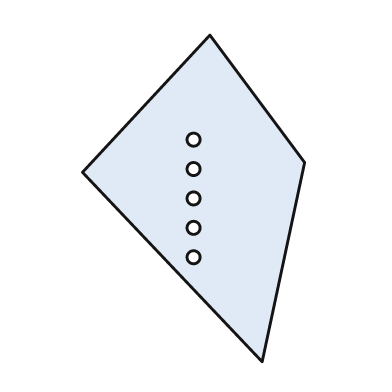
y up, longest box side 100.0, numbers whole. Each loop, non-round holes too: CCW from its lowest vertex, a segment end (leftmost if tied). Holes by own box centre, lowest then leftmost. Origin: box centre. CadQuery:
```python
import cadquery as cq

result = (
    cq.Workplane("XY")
    .moveTo(21.0, -50.0)
    .lineTo(34.0, 11.0)
    .lineTo(5.0, 50.0)
    .lineTo(-34.0, 8.0)
    .close()
    .moveTo(0.0, -18.0)
    .circle(2.0)
    .moveTo(0.0, -9.0)
    .circle(2.0)
    .moveTo(0.0, 0.0)
    .circle(2.0)
    .moveTo(0.0, 9.0)
    .circle(2.0)
    .moveTo(0.0, 18.0)
    .circle(2.0)
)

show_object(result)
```